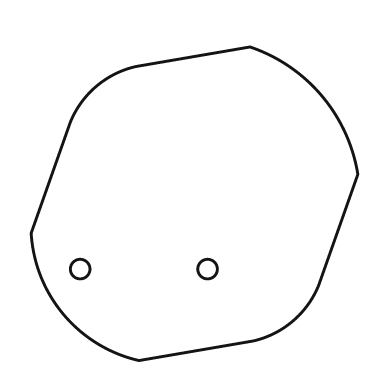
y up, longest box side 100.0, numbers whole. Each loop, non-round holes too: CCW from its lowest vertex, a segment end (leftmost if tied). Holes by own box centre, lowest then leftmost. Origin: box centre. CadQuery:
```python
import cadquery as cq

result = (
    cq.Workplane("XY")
    .moveTo(-17.0, -48.0)
    .lineTo(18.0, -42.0)
    .threePointArc((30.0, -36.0), (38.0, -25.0))
    .lineTo(50.0, 9.0)
    .threePointArc((39.0, 33.0), (17.0, 48.0))
    .lineTo(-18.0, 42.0)
    .threePointArc((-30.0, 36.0), (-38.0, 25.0))
    .lineTo(-50.0, -9.0)
    .threePointArc((-40.0, -34.0), (-17.0, -48.0))
    .close()
    .moveTo(-35.0, -20.0)
    .circle(3.0)
    .moveTo(4.0, -20.0)
    .circle(3.0)
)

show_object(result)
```